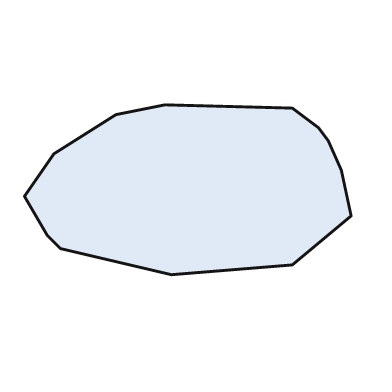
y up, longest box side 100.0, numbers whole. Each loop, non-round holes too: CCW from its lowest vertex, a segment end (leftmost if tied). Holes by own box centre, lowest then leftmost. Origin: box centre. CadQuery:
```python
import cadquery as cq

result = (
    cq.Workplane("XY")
    .moveTo(-5.0, -26.0)
    .lineTo(32.0, -23.0)
    .lineTo(50.0, -8.0)
    .lineTo(47.0, 6.0)
    .lineTo(43.0, 15.0)
    .lineTo(40.0, 19.0)
    .lineTo(32.0, 25.0)
    .lineTo(-7.0, 26.0)
    .lineTo(-22.0, 23.0)
    .lineTo(-41.0, 11.0)
    .lineTo(-50.0, -2.0)
    .lineTo(-43.0, -14.0)
    .lineTo(-39.0, -18.0)
    .close()
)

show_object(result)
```